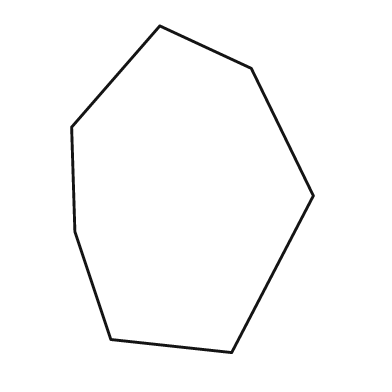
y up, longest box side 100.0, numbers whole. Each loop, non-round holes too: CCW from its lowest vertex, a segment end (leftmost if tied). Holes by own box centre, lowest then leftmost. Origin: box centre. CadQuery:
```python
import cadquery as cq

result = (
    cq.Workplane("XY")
    .moveTo(12.0, -50.0)
    .lineTo(37.0, -2.0)
    .lineTo(18.0, 37.0)
    .lineTo(-10.0, 50.0)
    .lineTo(-37.0, 19.0)
    .lineTo(-36.0, -13.0)
    .lineTo(-25.0, -46.0)
    .close()
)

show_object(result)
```